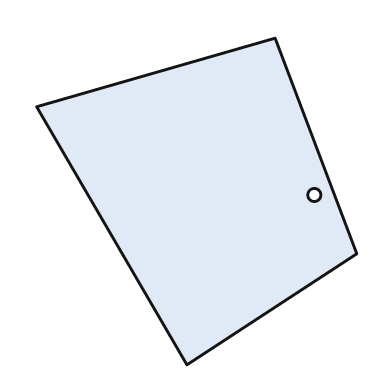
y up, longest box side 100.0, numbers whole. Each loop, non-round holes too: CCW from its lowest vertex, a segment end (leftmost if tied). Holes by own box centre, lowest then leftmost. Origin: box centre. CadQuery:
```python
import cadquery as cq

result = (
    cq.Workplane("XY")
    .moveTo(-3.0, -50.0)
    .lineTo(49.0, -16.0)
    .lineTo(24.0, 50.0)
    .lineTo(-49.0, 29.0)
    .close()
    .moveTo(36.0, 2.0)
    .circle(2.0)
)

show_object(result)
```